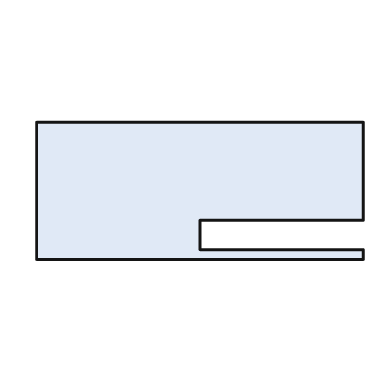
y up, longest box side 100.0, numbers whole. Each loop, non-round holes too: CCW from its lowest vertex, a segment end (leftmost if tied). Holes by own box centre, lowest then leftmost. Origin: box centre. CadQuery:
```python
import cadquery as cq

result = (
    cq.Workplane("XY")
    .moveTo(-50.0, -21.0)
    .lineTo(50.0, -21.0)
    .lineTo(50.0, -18.0)
    .lineTo(0.0, -18.0)
    .lineTo(0.0, -9.0)
    .lineTo(50.0, -9.0)
    .lineTo(50.0, 21.0)
    .lineTo(-50.0, 21.0)
    .close()
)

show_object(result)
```